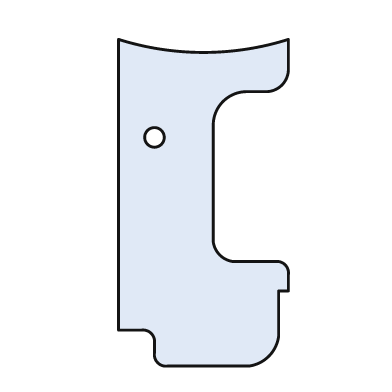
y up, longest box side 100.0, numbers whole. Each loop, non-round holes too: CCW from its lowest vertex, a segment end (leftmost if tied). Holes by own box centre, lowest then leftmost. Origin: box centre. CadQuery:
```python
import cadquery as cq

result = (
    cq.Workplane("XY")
    .moveTo(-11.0, -50.0)
    .lineTo(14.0, -50.0)
    .threePointArc((20.0, -47.0), (23.0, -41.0))
    .lineTo(23.0, -27.0)
    .lineTo(26.0, -27.0)
    .lineTo(26.0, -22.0)
    .threePointArc((25.0, -19.0), (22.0, -18.0))
    .lineTo(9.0, -18.0)
    .threePointArc((5.0, -16.0), (3.0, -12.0))
    .lineTo(3.0, 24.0)
    .threePointArc((6.0, 31.0), (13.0, 34.0))
    .lineTo(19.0, 34.0)
    .threePointArc((24.0, 36.0), (26.0, 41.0))
    .lineTo(26.0, 50.0)
    .threePointArc((0.0, 46.0), (-26.0, 50.0))
    .lineTo(-26.0, -39.0)
    .lineTo(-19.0, -39.0)
    .threePointArc((-16.0, -40.0), (-15.0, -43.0))
    .lineTo(-15.0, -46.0)
    .threePointArc((-14.0, -49.0), (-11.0, -50.0))
    .close()
    .moveTo(-15.0, 20.0)
    .circle(3.0)
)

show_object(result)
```